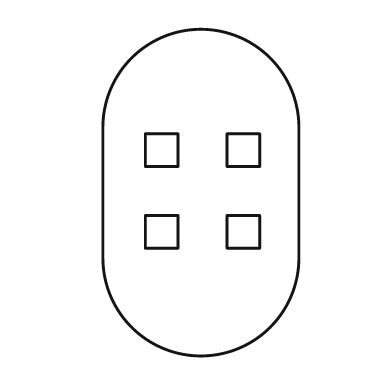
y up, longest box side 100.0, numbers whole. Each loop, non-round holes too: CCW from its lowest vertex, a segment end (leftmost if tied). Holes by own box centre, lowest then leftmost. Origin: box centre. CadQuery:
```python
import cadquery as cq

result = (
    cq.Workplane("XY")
    .moveTo(-30.0, -20.0)
    .threePointArc((0.0, -50.0), (30.0, -20.0))
    .lineTo(30.0, 20.0)
    .threePointArc((0.0, 50.0), (-30.0, 20.0))
    .close()
    .moveTo(-17.0, -17.0)
    .lineTo(-7.0, -17.0)
    .lineTo(-7.0, -7.0)
    .lineTo(-17.0, -7.0)
    .close()
    .moveTo(8.0, -17.0)
    .lineTo(18.0, -17.0)
    .lineTo(18.0, -7.0)
    .lineTo(8.0, -7.0)
    .close()
    .moveTo(-17.0, 8.0)
    .lineTo(-7.0, 8.0)
    .lineTo(-7.0, 18.0)
    .lineTo(-17.0, 18.0)
    .close()
    .moveTo(8.0, 8.0)
    .lineTo(18.0, 8.0)
    .lineTo(18.0, 18.0)
    .lineTo(8.0, 18.0)
    .close()
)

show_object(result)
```